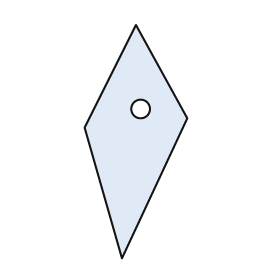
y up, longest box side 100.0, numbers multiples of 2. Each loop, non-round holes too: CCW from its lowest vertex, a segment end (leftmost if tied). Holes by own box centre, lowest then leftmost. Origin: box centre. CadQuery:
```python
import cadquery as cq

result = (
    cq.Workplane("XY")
    .moveTo(-6.0, -50.0)
    .lineTo(22.0, 10.0)
    .lineTo(0.0, 50.0)
    .lineTo(-22.0, 6.0)
    .close()
    .moveTo(2.0, 14.0)
    .circle(4.0)
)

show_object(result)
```